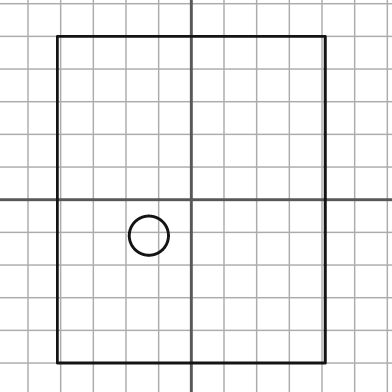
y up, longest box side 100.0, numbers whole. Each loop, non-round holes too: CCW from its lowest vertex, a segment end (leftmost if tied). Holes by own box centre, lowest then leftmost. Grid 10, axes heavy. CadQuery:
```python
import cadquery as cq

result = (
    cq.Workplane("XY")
    .moveTo(-41.0, -50.0)
    .lineTo(41.0, -50.0)
    .lineTo(41.0, 50.0)
    .lineTo(-41.0, 50.0)
    .close()
    .moveTo(-13.0, -11.0)
    .circle(6.0)
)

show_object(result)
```